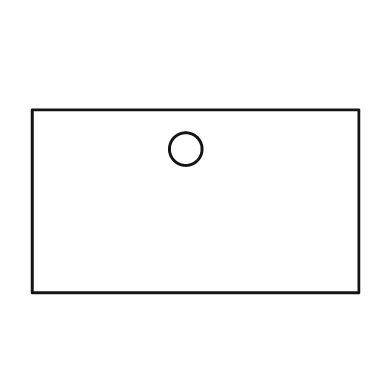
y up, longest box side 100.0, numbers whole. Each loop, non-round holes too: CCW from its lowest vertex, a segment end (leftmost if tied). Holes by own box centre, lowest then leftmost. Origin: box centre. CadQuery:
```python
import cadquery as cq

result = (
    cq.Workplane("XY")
    .moveTo(-50.0, -28.0)
    .lineTo(50.0, -28.0)
    .lineTo(50.0, 28.0)
    .lineTo(-50.0, 28.0)
    .close()
    .moveTo(-3.0, 16.0)
    .circle(5.0)
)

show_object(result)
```